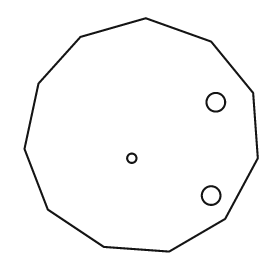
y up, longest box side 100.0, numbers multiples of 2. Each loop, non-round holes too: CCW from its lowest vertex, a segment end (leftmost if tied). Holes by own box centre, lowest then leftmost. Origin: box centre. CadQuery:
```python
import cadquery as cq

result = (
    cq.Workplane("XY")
    .moveTo(12.0, -50.0)
    .lineTo(36.0, -36.0)
    .lineTo(50.0, -10.0)
    .lineTo(48.0, 18.0)
    .lineTo(30.0, 40.0)
    .lineTo(2.0, 50.0)
    .lineTo(-26.0, 42.0)
    .lineTo(-44.0, 22.0)
    .lineTo(-50.0, -6.0)
    .lineTo(-40.0, -32.0)
    .lineTo(-16.0, -48.0)
    .close()
    .moveTo(30.0, -26.0)
    .circle(4.0)
    .moveTo(-4.0, -10.0)
    .circle(2.0)
    .moveTo(32.0, 14.0)
    .circle(4.0)
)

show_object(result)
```